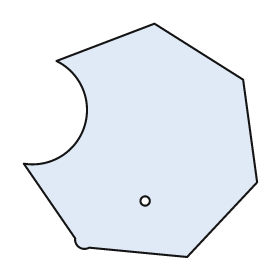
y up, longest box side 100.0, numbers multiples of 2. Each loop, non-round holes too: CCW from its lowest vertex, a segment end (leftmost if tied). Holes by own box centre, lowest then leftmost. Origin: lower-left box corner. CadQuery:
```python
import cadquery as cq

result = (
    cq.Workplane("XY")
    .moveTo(70.0, 0.0)
    .lineTo(100.0, 32.0)
    .lineTo(94.0, 76.0)
    .lineTo(56.0, 100.0)
    .lineTo(14.0, 84.0)
    .threePointArc((26.0, 56.0), (0.0, 40.0))
    .lineTo(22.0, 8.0)
    .threePointArc((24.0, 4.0), (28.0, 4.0))
    .close()
    .moveTo(52.0, 24.0)
    .circle(2.0)
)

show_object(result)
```